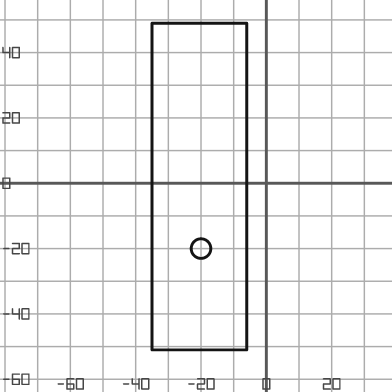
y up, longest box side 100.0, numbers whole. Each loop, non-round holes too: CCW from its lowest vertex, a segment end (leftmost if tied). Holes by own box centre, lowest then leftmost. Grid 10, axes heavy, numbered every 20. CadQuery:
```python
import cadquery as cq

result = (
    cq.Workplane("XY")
    .moveTo(-35.0, -51.0)
    .lineTo(-6.0, -51.0)
    .lineTo(-6.0, 49.0)
    .lineTo(-35.0, 49.0)
    .close()
    .moveTo(-20.0, -20.0)
    .circle(3.0)
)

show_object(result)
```